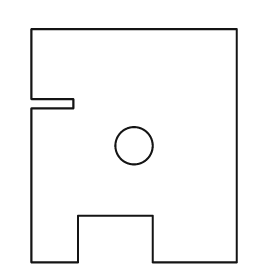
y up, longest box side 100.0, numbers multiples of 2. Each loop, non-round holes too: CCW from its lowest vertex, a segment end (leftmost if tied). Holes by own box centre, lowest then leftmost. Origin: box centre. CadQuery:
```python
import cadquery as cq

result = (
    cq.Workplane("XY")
    .moveTo(-44.0, -50.0)
    .lineTo(-24.0, -50.0)
    .lineTo(-24.0, -30.0)
    .lineTo(8.0, -30.0)
    .lineTo(8.0, -50.0)
    .lineTo(44.0, -50.0)
    .lineTo(44.0, 50.0)
    .lineTo(-44.0, 50.0)
    .lineTo(-44.0, 20.0)
    .lineTo(-26.0, 20.0)
    .lineTo(-26.0, 16.0)
    .lineTo(-44.0, 16.0)
    .close()
    .moveTo(0.0, 0.0)
    .circle(8.0)
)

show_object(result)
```